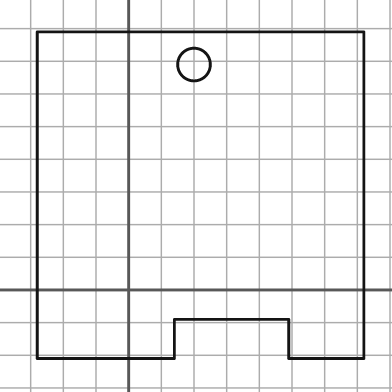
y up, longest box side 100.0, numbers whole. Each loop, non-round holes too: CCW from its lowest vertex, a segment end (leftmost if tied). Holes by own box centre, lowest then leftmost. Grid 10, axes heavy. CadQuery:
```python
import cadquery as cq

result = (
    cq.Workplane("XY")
    .moveTo(-28.0, -21.0)
    .lineTo(14.0, -21.0)
    .lineTo(14.0, -9.0)
    .lineTo(49.0, -9.0)
    .lineTo(49.0, -21.0)
    .lineTo(72.0, -21.0)
    .lineTo(72.0, 79.0)
    .lineTo(-28.0, 79.0)
    .close()
    .moveTo(20.0, 69.0)
    .circle(5.0)
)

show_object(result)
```